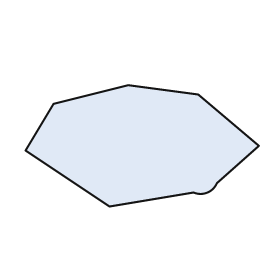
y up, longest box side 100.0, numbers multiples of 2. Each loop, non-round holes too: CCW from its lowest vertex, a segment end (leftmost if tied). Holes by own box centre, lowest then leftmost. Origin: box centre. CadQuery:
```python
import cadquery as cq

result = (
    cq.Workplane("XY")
    .moveTo(-14.0, -26.0)
    .lineTo(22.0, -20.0)
    .threePointArc((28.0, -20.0), (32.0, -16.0))
    .lineTo(50.0, 0.0)
    .lineTo(24.0, 22.0)
    .lineTo(-6.0, 26.0)
    .lineTo(-38.0, 18.0)
    .lineTo(-50.0, -2.0)
    .close()
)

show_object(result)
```